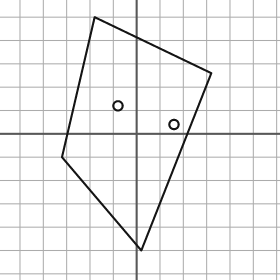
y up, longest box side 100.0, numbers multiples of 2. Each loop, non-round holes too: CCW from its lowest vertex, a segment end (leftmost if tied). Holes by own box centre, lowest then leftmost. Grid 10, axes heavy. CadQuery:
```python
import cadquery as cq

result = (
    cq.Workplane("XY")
    .moveTo(2.0, -50.0)
    .lineTo(32.0, 26.0)
    .lineTo(-18.0, 50.0)
    .lineTo(-32.0, -10.0)
    .close()
    .moveTo(16.0, 4.0)
    .circle(2.0)
    .moveTo(-8.0, 12.0)
    .circle(2.0)
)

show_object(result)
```